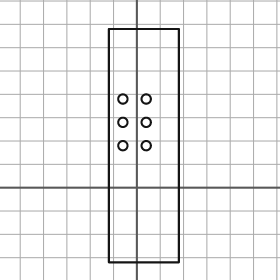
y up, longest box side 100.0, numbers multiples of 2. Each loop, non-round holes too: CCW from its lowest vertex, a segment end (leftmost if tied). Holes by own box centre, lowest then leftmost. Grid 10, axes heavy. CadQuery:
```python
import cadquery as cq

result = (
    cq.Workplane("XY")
    .moveTo(-12.0, -32.0)
    .lineTo(18.0, -32.0)
    .lineTo(18.0, 68.0)
    .lineTo(-12.0, 68.0)
    .close()
    .moveTo(-6.0, 18.0)
    .circle(2.0)
    .moveTo(4.0, 18.0)
    .circle(2.0)
    .moveTo(-6.0, 28.0)
    .circle(2.0)
    .moveTo(4.0, 28.0)
    .circle(2.0)
    .moveTo(-6.0, 38.0)
    .circle(2.0)
    .moveTo(4.0, 38.0)
    .circle(2.0)
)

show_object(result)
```